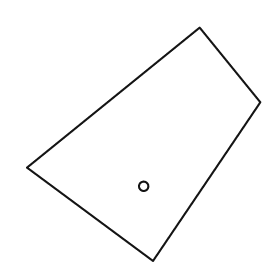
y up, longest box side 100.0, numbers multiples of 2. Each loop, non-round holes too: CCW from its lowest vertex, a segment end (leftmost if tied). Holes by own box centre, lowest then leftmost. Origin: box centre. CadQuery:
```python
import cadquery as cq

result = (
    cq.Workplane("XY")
    .moveTo(4.0, -50.0)
    .lineTo(50.0, 18.0)
    .lineTo(24.0, 50.0)
    .lineTo(-50.0, -10.0)
    .close()
    .moveTo(0.0, -18.0)
    .circle(2.0)
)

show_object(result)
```